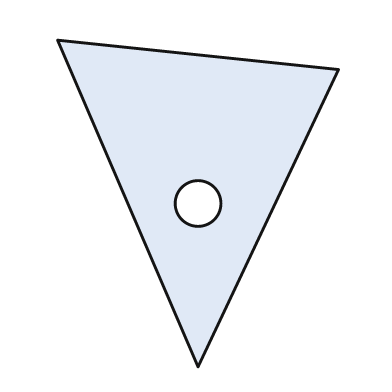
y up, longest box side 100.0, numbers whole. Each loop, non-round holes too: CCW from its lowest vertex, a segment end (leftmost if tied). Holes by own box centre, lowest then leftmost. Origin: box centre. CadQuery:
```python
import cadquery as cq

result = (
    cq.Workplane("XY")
    .moveTo(0.0, -50.0)
    .lineTo(43.0, 41.0)
    .lineTo(-43.0, 50.0)
    .close()
    .moveTo(0.0, 0.0)
    .circle(7.0)
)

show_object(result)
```